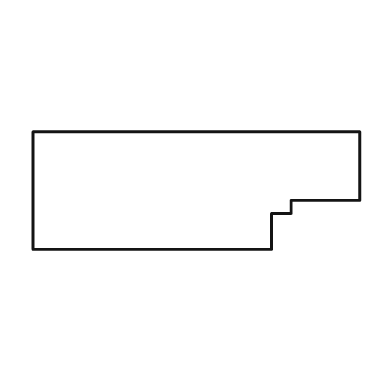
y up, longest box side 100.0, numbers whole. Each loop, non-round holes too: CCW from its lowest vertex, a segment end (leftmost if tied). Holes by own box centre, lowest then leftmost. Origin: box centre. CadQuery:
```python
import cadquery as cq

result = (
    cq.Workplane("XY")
    .moveTo(-50.0, -18.0)
    .lineTo(23.0, -18.0)
    .lineTo(23.0, -7.0)
    .lineTo(29.0, -7.0)
    .lineTo(29.0, -3.0)
    .lineTo(50.0, -3.0)
    .lineTo(50.0, 18.0)
    .lineTo(-50.0, 18.0)
    .close()
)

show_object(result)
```